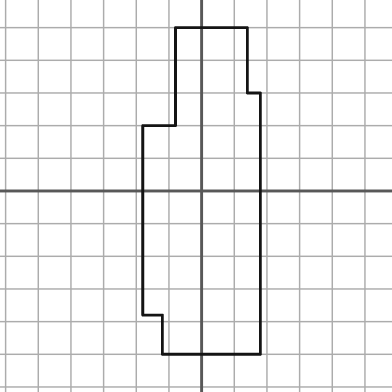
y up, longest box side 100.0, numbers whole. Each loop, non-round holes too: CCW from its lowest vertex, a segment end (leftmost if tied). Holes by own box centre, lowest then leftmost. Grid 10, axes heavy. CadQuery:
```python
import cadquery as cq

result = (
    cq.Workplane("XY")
    .moveTo(-12.0, -50.0)
    .lineTo(18.0, -50.0)
    .lineTo(18.0, 30.0)
    .lineTo(14.0, 30.0)
    .lineTo(14.0, 50.0)
    .lineTo(-8.0, 50.0)
    .lineTo(-8.0, 20.0)
    .lineTo(-18.0, 20.0)
    .lineTo(-18.0, -38.0)
    .lineTo(-12.0, -38.0)
    .close()
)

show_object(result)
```